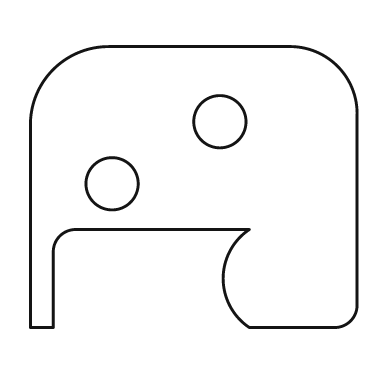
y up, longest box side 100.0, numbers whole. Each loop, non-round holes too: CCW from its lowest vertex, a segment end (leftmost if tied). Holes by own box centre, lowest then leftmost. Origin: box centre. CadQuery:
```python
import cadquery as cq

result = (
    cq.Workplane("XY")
    .moveTo(-50.0, -43.0)
    .lineTo(-43.0, -43.0)
    .lineTo(-43.0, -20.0)
    .threePointArc((-41.0, -15.0), (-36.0, -13.0))
    .lineTo(17.0, -13.0)
    .threePointArc((9.0, -28.0), (17.0, -43.0))
    .lineTo(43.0, -43.0)
    .threePointArc((48.0, -41.0), (50.0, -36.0))
    .lineTo(50.0, 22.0)
    .threePointArc((44.0, 37.0), (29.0, 43.0))
    .lineTo(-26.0, 43.0)
    .threePointArc((-43.0, 36.0), (-50.0, 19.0))
    .close()
    .moveTo(-25.0, 1.0)
    .circle(8.0)
    .moveTo(8.0, 20.0)
    .circle(8.0)
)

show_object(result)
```